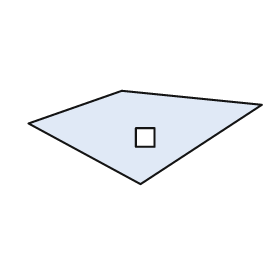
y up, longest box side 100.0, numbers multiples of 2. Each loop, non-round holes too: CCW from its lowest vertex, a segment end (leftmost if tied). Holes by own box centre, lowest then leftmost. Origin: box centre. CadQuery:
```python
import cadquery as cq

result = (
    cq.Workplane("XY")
    .moveTo(-2.0, -20.0)
    .lineTo(50.0, 14.0)
    .lineTo(-10.0, 20.0)
    .lineTo(-50.0, 6.0)
    .close()
    .moveTo(-4.0, -4.0)
    .lineTo(4.0, -4.0)
    .lineTo(4.0, 4.0)
    .lineTo(-4.0, 4.0)
    .close()
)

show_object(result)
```